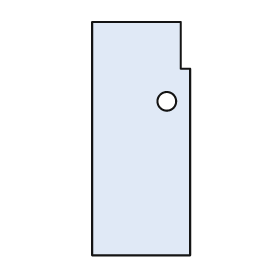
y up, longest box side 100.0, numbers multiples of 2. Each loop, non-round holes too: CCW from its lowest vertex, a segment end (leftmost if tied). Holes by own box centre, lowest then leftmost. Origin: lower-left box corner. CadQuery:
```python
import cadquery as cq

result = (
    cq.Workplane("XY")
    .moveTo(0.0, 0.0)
    .lineTo(42.0, 0.0)
    .lineTo(42.0, 80.0)
    .lineTo(38.0, 80.0)
    .lineTo(38.0, 100.0)
    .lineTo(0.0, 100.0)
    .close()
    .moveTo(32.0, 66.0)
    .circle(4.0)
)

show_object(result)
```